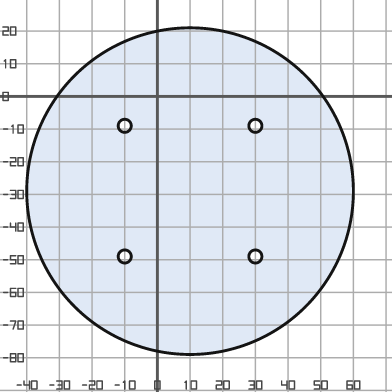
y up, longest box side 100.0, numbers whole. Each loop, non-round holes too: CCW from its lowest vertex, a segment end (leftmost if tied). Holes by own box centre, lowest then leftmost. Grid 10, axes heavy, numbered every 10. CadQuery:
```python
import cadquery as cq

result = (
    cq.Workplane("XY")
    .moveTo(10.0, -29.0)
    .circle(50.0)
    .moveTo(-10.0, -49.0)
    .circle(2.0)
    .moveTo(30.0, -49.0)
    .circle(2.0)
    .moveTo(-10.0, -9.0)
    .circle(2.0)
    .moveTo(30.0, -9.0)
    .circle(2.0)
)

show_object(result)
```